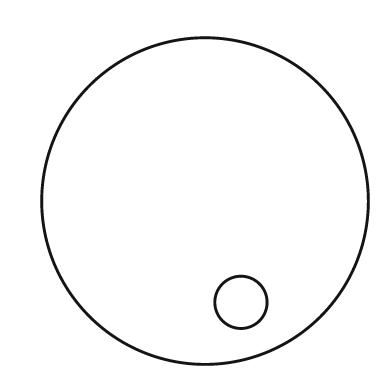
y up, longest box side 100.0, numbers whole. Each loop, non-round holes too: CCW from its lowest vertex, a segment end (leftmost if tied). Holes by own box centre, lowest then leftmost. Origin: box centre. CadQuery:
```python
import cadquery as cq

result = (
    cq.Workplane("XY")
    .moveTo(0.0, 0.0)
    .circle(50.0)
    .moveTo(11.0, -31.0)
    .circle(8.0)
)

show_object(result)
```